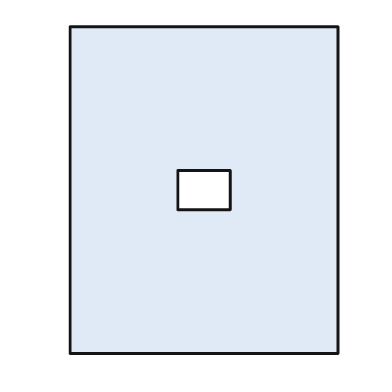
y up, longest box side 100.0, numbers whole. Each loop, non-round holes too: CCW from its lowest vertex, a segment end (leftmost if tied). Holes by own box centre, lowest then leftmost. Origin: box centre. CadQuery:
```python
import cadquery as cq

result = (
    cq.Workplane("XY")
    .moveTo(-41.0, -50.0)
    .lineTo(41.0, -50.0)
    .lineTo(41.0, 50.0)
    .lineTo(-41.0, 50.0)
    .close()
    .moveTo(-8.0, -6.0)
    .lineTo(8.0, -6.0)
    .lineTo(8.0, 6.0)
    .lineTo(-8.0, 6.0)
    .close()
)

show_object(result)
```